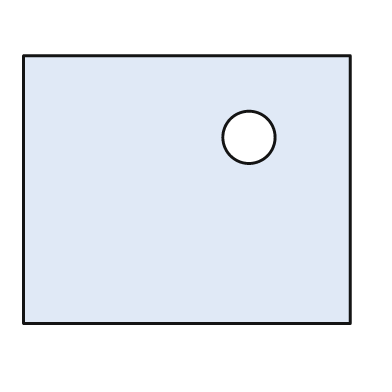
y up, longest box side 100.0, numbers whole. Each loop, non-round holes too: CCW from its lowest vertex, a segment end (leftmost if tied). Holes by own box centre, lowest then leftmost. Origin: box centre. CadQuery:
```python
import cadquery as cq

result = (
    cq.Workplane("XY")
    .moveTo(-50.0, -41.0)
    .lineTo(50.0, -41.0)
    .lineTo(50.0, 41.0)
    .lineTo(-50.0, 41.0)
    .close()
    .moveTo(19.0, 16.0)
    .circle(8.0)
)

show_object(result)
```